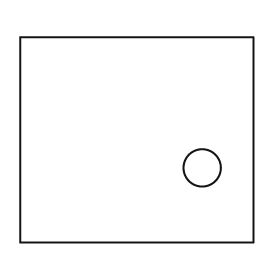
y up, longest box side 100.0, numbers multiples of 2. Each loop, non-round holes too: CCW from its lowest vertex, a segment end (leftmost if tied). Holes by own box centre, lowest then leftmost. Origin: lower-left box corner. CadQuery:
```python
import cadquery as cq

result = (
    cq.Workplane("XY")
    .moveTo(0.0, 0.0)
    .lineTo(100.0, 0.0)
    .lineTo(100.0, 88.0)
    .lineTo(0.0, 88.0)
    .close()
    .moveTo(78.0, 32.0)
    .circle(8.0)
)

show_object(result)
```